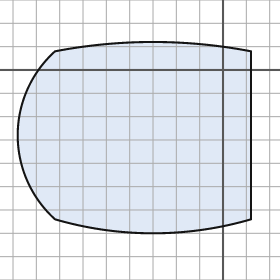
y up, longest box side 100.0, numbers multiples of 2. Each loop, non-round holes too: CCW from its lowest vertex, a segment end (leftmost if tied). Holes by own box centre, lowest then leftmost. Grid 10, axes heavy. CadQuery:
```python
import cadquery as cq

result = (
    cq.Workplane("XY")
    .moveTo(-72.0, -64.0)
    .threePointArc((-30.0, -70.0), (12.0, -64.0))
    .lineTo(12.0, 8.0)
    .threePointArc((-30.0, 12.0), (-72.0, 8.0))
    .threePointArc((-88.0, -28.0), (-72.0, -64.0))
    .close()
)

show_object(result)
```